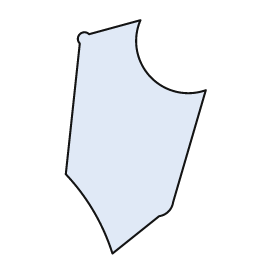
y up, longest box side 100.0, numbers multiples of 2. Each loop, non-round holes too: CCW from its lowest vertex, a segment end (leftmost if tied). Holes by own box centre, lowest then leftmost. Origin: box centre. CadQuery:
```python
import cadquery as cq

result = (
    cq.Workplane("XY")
    .moveTo(-10.0, -50.0)
    .lineTo(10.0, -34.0)
    .threePointArc((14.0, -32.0), (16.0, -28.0))
    .lineTo(30.0, 20.0)
    .threePointArc((6.0, 26.0), (2.0, 50.0))
    .lineTo(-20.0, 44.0)
    .threePointArc((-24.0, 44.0), (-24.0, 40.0))
    .lineTo(-30.0, -16.0)
    .threePointArc((-18.0, -32.0), (-10.0, -50.0))
    .close()
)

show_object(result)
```